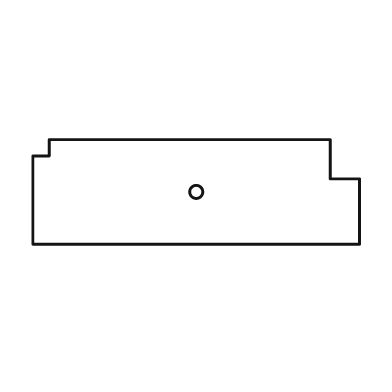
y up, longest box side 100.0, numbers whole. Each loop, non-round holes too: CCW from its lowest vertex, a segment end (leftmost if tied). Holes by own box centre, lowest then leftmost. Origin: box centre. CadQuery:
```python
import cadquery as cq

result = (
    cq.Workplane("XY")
    .moveTo(-50.0, -16.0)
    .lineTo(50.0, -16.0)
    .lineTo(50.0, 4.0)
    .lineTo(41.0, 4.0)
    .lineTo(41.0, 16.0)
    .lineTo(-45.0, 16.0)
    .lineTo(-45.0, 11.0)
    .lineTo(-50.0, 11.0)
    .close()
    .moveTo(0.0, 0.0)
    .circle(2.0)
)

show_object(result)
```